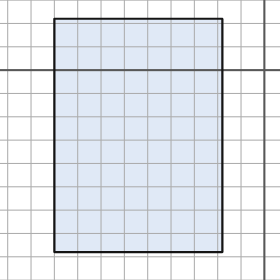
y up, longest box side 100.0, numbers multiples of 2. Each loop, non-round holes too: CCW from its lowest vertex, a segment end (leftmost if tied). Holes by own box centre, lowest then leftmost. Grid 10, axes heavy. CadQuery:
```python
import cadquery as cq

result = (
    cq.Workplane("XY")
    .moveTo(-90.0, -78.0)
    .lineTo(-18.0, -78.0)
    .lineTo(-18.0, 22.0)
    .lineTo(-90.0, 22.0)
    .close()
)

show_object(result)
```